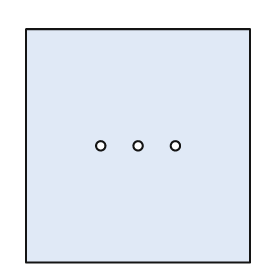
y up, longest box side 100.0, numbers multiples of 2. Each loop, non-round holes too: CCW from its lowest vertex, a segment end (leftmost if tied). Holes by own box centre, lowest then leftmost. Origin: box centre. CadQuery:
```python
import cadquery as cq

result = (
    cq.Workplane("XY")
    .moveTo(-48.0, -50.0)
    .lineTo(48.0, -50.0)
    .lineTo(48.0, 50.0)
    .lineTo(-48.0, 50.0)
    .close()
    .moveTo(-16.0, 0.0)
    .circle(2.0)
    .moveTo(0.0, 0.0)
    .circle(2.0)
    .moveTo(16.0, 0.0)
    .circle(2.0)
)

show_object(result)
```